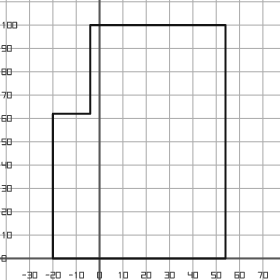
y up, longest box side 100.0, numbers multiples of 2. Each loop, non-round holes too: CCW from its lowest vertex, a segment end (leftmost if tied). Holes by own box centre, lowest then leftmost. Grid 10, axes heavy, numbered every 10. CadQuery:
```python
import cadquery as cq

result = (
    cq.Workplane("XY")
    .moveTo(-20.0, 0.0)
    .lineTo(54.0, 0.0)
    .lineTo(54.0, 100.0)
    .lineTo(-4.0, 100.0)
    .lineTo(-4.0, 62.0)
    .lineTo(-20.0, 62.0)
    .close()
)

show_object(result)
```